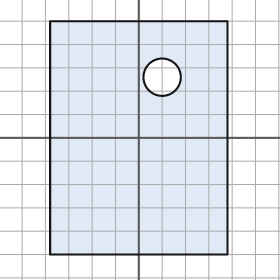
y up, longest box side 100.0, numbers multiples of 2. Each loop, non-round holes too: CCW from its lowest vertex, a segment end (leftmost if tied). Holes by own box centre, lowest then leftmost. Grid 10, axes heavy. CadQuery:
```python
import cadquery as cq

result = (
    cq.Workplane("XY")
    .moveTo(-38.0, -50.0)
    .lineTo(38.0, -50.0)
    .lineTo(38.0, 50.0)
    .lineTo(-38.0, 50.0)
    .close()
    .moveTo(10.0, 26.0)
    .circle(8.0)
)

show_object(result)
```